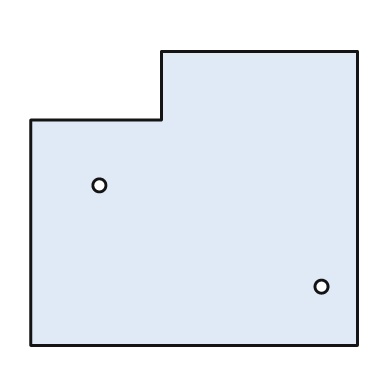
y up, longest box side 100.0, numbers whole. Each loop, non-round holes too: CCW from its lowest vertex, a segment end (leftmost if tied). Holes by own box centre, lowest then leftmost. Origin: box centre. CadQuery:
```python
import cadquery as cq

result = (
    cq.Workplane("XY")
    .moveTo(-50.0, -45.0)
    .lineTo(50.0, -45.0)
    .lineTo(50.0, 45.0)
    .lineTo(-10.0, 45.0)
    .lineTo(-10.0, 24.0)
    .lineTo(-50.0, 24.0)
    .close()
    .moveTo(39.0, -27.0)
    .circle(2.0)
    .moveTo(-29.0, 4.0)
    .circle(2.0)
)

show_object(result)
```